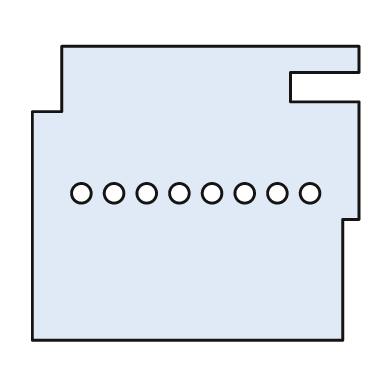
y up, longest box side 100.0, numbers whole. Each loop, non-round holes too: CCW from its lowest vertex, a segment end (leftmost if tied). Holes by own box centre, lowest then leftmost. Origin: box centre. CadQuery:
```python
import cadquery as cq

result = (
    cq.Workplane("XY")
    .moveTo(-50.0, -45.0)
    .lineTo(45.0, -45.0)
    .lineTo(45.0, -8.0)
    .lineTo(50.0, -8.0)
    .lineTo(50.0, 28.0)
    .lineTo(29.0, 28.0)
    .lineTo(29.0, 37.0)
    .lineTo(50.0, 37.0)
    .lineTo(50.0, 45.0)
    .lineTo(-41.0, 45.0)
    .lineTo(-41.0, 25.0)
    .lineTo(-50.0, 25.0)
    .close()
    .moveTo(-35.0, 0.0)
    .circle(3.0)
    .moveTo(-25.0, 0.0)
    .circle(3.0)
    .moveTo(-15.0, 0.0)
    .circle(3.0)
    .moveTo(-5.0, 0.0)
    .circle(3.0)
    .moveTo(5.0, 0.0)
    .circle(3.0)
    .moveTo(15.0, 0.0)
    .circle(3.0)
    .moveTo(25.0, 0.0)
    .circle(3.0)
    .moveTo(35.0, 0.0)
    .circle(3.0)
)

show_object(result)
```